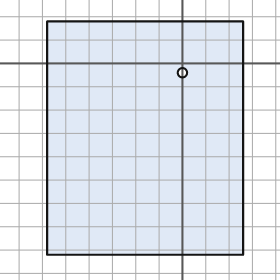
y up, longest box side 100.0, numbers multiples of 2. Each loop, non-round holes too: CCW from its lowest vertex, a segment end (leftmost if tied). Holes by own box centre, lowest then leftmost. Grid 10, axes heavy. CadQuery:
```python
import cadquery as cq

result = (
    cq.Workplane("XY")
    .moveTo(-58.0, -82.0)
    .lineTo(26.0, -82.0)
    .lineTo(26.0, 18.0)
    .lineTo(-58.0, 18.0)
    .close()
    .moveTo(0.0, -4.0)
    .circle(2.0)
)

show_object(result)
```